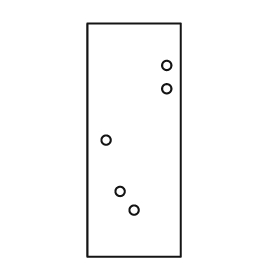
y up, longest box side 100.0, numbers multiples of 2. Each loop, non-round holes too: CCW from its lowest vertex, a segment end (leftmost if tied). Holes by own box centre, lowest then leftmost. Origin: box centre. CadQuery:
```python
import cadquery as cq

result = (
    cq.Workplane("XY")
    .moveTo(-20.0, -50.0)
    .lineTo(20.0, -50.0)
    .lineTo(20.0, 50.0)
    .lineTo(-20.0, 50.0)
    .close()
    .moveTo(0.0, -30.0)
    .circle(2.0)
    .moveTo(-6.0, -22.0)
    .circle(2.0)
    .moveTo(-12.0, 0.0)
    .circle(2.0)
    .moveTo(14.0, 22.0)
    .circle(2.0)
    .moveTo(14.0, 32.0)
    .circle(2.0)
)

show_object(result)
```